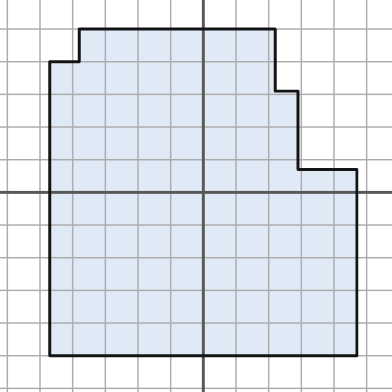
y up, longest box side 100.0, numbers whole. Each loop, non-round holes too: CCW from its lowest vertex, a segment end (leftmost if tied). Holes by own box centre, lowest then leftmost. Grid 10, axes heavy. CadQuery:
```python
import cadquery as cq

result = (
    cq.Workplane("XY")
    .moveTo(-47.0, -50.0)
    .lineTo(47.0, -50.0)
    .lineTo(47.0, 7.0)
    .lineTo(29.0, 7.0)
    .lineTo(29.0, 31.0)
    .lineTo(22.0, 31.0)
    .lineTo(22.0, 50.0)
    .lineTo(-38.0, 50.0)
    .lineTo(-38.0, 40.0)
    .lineTo(-47.0, 40.0)
    .close()
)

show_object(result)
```